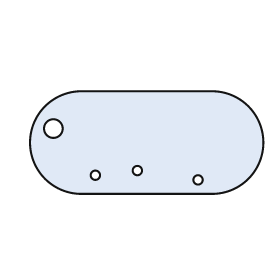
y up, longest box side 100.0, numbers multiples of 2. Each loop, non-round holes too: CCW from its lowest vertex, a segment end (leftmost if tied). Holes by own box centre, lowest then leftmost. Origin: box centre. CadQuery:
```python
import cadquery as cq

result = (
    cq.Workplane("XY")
    .moveTo(-28.0, -22.0)
    .lineTo(28.0, -22.0)
    .threePointArc((50.0, 0.0), (28.0, 22.0))
    .lineTo(-28.0, 22.0)
    .threePointArc((-50.0, 0.0), (-28.0, -22.0))
    .close()
    .moveTo(22.0, -16.0)
    .circle(2.0)
    .moveTo(-22.0, -14.0)
    .circle(2.0)
    .moveTo(-4.0, -12.0)
    .circle(2.0)
    .moveTo(-40.0, 6.0)
    .circle(4.0)
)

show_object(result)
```